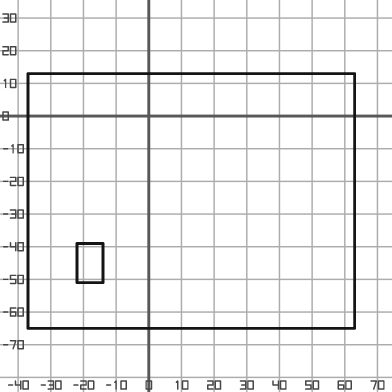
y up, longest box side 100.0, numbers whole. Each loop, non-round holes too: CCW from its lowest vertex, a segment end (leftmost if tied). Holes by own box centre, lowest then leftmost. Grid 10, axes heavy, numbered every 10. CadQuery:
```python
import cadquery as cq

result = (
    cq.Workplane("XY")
    .moveTo(-37.0, -65.0)
    .lineTo(63.0, -65.0)
    .lineTo(63.0, 13.0)
    .lineTo(-37.0, 13.0)
    .close()
    .moveTo(-22.0, -51.0)
    .lineTo(-14.0, -51.0)
    .lineTo(-14.0, -39.0)
    .lineTo(-22.0, -39.0)
    .close()
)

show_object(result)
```